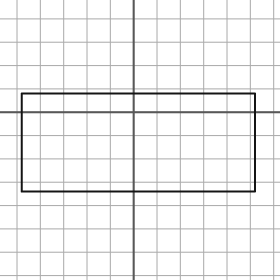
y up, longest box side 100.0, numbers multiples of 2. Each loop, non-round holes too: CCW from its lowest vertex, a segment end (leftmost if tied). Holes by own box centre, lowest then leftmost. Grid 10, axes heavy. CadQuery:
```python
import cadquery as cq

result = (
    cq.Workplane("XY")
    .moveTo(-48.0, -34.0)
    .lineTo(52.0, -34.0)
    .lineTo(52.0, 8.0)
    .lineTo(-48.0, 8.0)
    .close()
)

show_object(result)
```